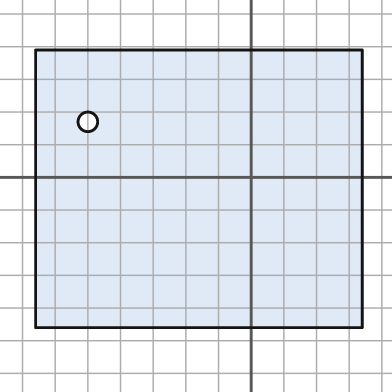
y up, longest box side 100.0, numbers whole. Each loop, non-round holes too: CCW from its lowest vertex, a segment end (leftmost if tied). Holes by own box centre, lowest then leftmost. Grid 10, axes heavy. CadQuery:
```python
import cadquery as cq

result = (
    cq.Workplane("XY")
    .moveTo(-66.0, -46.0)
    .lineTo(34.0, -46.0)
    .lineTo(34.0, 39.0)
    .lineTo(-66.0, 39.0)
    .close()
    .moveTo(-50.0, 17.0)
    .circle(3.0)
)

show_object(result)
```